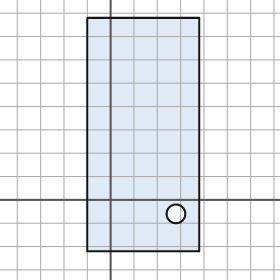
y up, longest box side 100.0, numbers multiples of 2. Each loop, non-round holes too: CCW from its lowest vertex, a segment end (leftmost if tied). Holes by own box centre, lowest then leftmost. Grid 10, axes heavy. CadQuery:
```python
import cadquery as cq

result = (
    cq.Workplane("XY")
    .moveTo(-10.0, -22.0)
    .lineTo(38.0, -22.0)
    .lineTo(38.0, 78.0)
    .lineTo(-10.0, 78.0)
    .close()
    .moveTo(28.0, -6.0)
    .circle(4.0)
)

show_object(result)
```